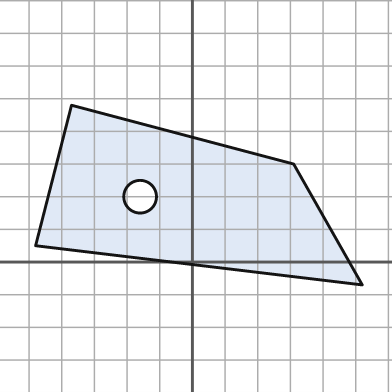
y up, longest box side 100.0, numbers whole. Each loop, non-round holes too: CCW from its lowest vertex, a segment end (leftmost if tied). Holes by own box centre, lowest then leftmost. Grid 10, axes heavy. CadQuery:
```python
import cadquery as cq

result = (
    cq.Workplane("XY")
    .moveTo(52.0, -7.0)
    .lineTo(31.0, 30.0)
    .lineTo(-37.0, 48.0)
    .lineTo(-48.0, 5.0)
    .close()
    .moveTo(-16.0, 20.0)
    .circle(5.0)
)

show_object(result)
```